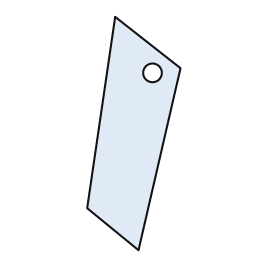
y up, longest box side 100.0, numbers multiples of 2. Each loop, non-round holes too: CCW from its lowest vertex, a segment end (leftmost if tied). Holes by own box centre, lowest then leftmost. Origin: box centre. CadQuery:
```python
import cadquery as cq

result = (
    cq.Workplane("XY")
    .moveTo(2.0, -50.0)
    .lineTo(20.0, 28.0)
    .lineTo(-8.0, 50.0)
    .lineTo(-20.0, -32.0)
    .close()
    .moveTo(8.0, 26.0)
    .circle(4.0)
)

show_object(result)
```